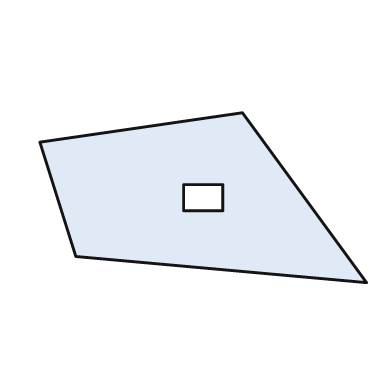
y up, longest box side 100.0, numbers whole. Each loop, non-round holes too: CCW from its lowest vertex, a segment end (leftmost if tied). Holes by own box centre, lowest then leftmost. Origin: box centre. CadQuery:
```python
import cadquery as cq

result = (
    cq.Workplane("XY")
    .moveTo(50.0, -26.0)
    .lineTo(12.0, 26.0)
    .lineTo(-50.0, 17.0)
    .lineTo(-39.0, -18.0)
    .close()
    .moveTo(-6.0, -4.0)
    .lineTo(6.0, -4.0)
    .lineTo(6.0, 4.0)
    .lineTo(-6.0, 4.0)
    .close()
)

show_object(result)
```